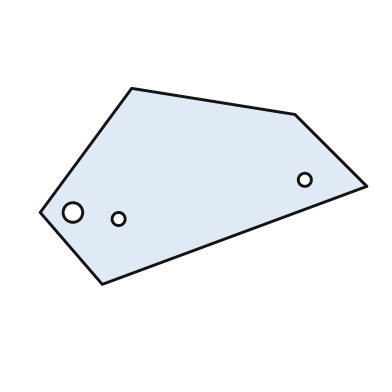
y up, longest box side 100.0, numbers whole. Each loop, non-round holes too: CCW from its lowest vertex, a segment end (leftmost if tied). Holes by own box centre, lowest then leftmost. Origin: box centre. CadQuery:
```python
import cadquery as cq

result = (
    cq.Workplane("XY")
    .moveTo(-31.0, -30.0)
    .lineTo(50.0, 0.0)
    .lineTo(28.0, 22.0)
    .lineTo(-22.0, 30.0)
    .lineTo(-50.0, -8.0)
    .close()
    .moveTo(-26.0, -10.0)
    .circle(2.0)
    .moveTo(-40.0, -8.0)
    .circle(3.0)
    .moveTo(31.0, 2.0)
    .circle(2.0)
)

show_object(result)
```